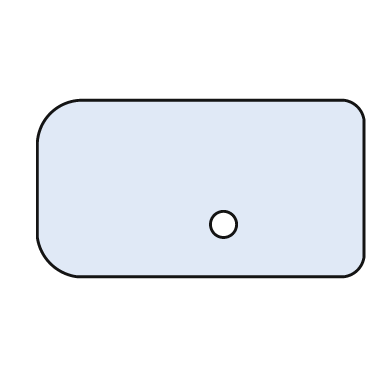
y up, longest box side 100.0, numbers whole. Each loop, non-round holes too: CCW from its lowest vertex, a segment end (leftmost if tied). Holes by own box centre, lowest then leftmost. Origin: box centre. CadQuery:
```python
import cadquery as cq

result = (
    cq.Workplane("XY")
    .moveTo(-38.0, -27.0)
    .lineTo(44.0, -27.0)
    .threePointArc((48.0, -25.0), (50.0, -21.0))
    .lineTo(50.0, 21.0)
    .threePointArc((48.0, 25.0), (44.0, 27.0))
    .lineTo(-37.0, 27.0)
    .threePointArc((-46.0, 23.0), (-50.0, 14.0))
    .lineTo(-50.0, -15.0)
    .threePointArc((-46.0, -23.0), (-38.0, -27.0))
    .close()
    .moveTo(7.0, -11.0)
    .circle(4.0)
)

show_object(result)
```